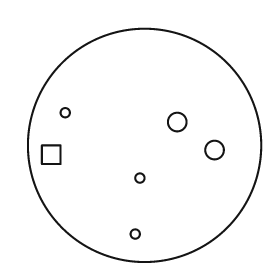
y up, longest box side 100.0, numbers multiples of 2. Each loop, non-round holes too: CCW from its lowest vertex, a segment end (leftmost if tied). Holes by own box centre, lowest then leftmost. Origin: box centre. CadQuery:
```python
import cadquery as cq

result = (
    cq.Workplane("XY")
    .moveTo(0.0, 0.0)
    .circle(50.0)
    .moveTo(-4.0, -38.0)
    .circle(2.0)
    .moveTo(-2.0, -14.0)
    .circle(2.0)
    .moveTo(-44.0, -8.0)
    .lineTo(-36.0, -8.0)
    .lineTo(-36.0, 0.0)
    .lineTo(-44.0, 0.0)
    .close()
    .moveTo(30.0, -2.0)
    .circle(4.0)
    .moveTo(14.0, 10.0)
    .circle(4.0)
    .moveTo(-34.0, 14.0)
    .circle(2.0)
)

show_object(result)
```